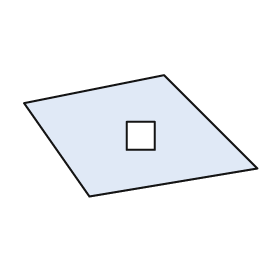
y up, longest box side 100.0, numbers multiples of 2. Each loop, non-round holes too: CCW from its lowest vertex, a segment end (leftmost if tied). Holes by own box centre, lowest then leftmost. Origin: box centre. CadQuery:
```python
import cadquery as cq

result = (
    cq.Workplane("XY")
    .moveTo(-22.0, -26.0)
    .lineTo(50.0, -14.0)
    .lineTo(10.0, 26.0)
    .lineTo(-50.0, 14.0)
    .close()
    .moveTo(-6.0, -6.0)
    .lineTo(6.0, -6.0)
    .lineTo(6.0, 6.0)
    .lineTo(-6.0, 6.0)
    .close()
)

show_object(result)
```